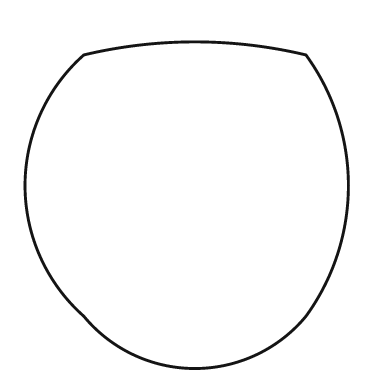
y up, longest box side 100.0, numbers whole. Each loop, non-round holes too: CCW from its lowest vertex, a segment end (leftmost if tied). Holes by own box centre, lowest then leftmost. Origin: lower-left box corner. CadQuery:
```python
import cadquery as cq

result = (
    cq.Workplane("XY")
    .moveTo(18.0, 16.0)
    .threePointArc((52.0, 0.0), (86.0, 16.0))
    .threePointArc((99.0, 56.0), (86.0, 96.0))
    .threePointArc((52.0, 100.0), (18.0, 96.0))
    .threePointArc((0.0, 56.0), (18.0, 16.0))
    .close()
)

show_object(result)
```